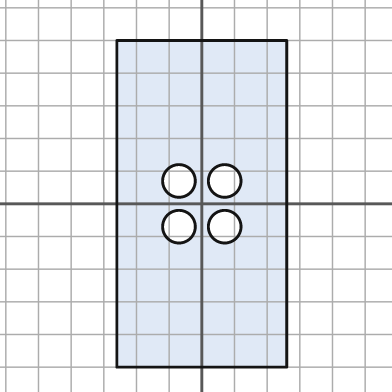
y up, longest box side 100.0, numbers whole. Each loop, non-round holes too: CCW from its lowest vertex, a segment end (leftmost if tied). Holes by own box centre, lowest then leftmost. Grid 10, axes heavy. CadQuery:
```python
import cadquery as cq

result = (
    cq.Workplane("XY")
    .moveTo(-26.0, -50.0)
    .lineTo(26.0, -50.0)
    .lineTo(26.0, 50.0)
    .lineTo(-26.0, 50.0)
    .close()
    .moveTo(-7.0, -7.0)
    .circle(5.0)
    .moveTo(7.0, -7.0)
    .circle(5.0)
    .moveTo(-7.0, 7.0)
    .circle(5.0)
    .moveTo(7.0, 7.0)
    .circle(5.0)
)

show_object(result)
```